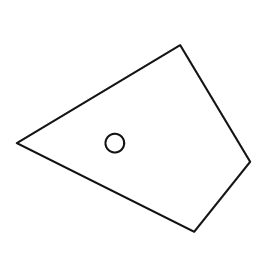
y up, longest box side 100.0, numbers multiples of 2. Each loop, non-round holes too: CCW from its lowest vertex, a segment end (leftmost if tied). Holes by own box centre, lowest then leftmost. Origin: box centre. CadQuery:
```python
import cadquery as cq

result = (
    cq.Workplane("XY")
    .moveTo(26.0, -40.0)
    .lineTo(50.0, -10.0)
    .lineTo(20.0, 40.0)
    .lineTo(-50.0, -2.0)
    .close()
    .moveTo(-8.0, -2.0)
    .circle(4.0)
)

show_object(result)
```